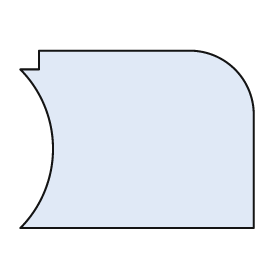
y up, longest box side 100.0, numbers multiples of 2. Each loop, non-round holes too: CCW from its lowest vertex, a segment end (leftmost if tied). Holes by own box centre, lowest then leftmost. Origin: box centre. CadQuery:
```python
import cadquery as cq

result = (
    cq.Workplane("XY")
    .moveTo(-50.0, -38.0)
    .lineTo(50.0, -38.0)
    .lineTo(50.0, 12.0)
    .threePointArc((42.0, 30.0), (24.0, 38.0))
    .lineTo(-42.0, 38.0)
    .lineTo(-42.0, 30.0)
    .lineTo(-50.0, 30.0)
    .threePointArc((-36.0, -4.0), (-50.0, -38.0))
    .close()
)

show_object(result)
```